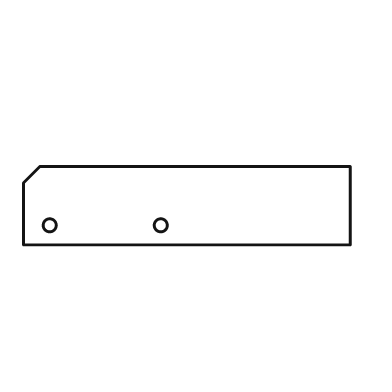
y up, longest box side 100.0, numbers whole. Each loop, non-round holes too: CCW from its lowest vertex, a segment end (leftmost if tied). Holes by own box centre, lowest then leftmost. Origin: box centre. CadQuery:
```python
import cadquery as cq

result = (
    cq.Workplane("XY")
    .moveTo(-50.0, -12.0)
    .lineTo(50.0, -12.0)
    .lineTo(50.0, 12.0)
    .lineTo(-45.0, 12.0)
    .lineTo(-50.0, 7.0)
    .close()
    .moveTo(-42.0, -6.0)
    .circle(2.0)
    .moveTo(-8.0, -6.0)
    .circle(2.0)
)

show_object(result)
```